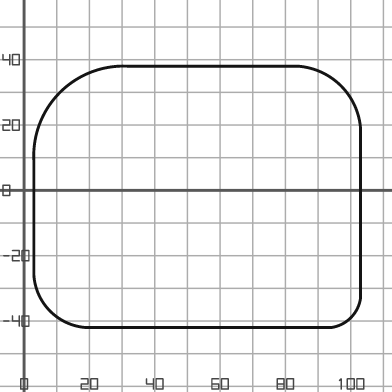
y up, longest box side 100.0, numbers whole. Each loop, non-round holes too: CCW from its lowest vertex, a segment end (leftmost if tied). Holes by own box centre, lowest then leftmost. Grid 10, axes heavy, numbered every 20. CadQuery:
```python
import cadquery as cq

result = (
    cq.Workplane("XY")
    .moveTo(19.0, -42.0)
    .lineTo(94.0, -42.0)
    .threePointArc((100.0, -39.0), (103.0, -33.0))
    .lineTo(103.0, 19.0)
    .threePointArc((97.0, 32.0), (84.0, 38.0))
    .lineTo(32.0, 38.0)
    .threePointArc((11.0, 30.0), (3.0, 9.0))
    .lineTo(3.0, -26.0)
    .threePointArc((8.0, -37.0), (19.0, -42.0))
    .close()
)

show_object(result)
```